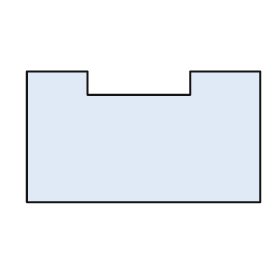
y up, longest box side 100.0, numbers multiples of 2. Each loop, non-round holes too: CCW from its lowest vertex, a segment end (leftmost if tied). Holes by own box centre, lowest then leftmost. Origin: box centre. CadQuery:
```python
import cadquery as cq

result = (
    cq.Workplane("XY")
    .moveTo(-50.0, -28.0)
    .lineTo(50.0, -28.0)
    .lineTo(50.0, 28.0)
    .lineTo(20.0, 28.0)
    .lineTo(20.0, 18.0)
    .lineTo(-24.0, 18.0)
    .lineTo(-24.0, 28.0)
    .lineTo(-50.0, 28.0)
    .close()
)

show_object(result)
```